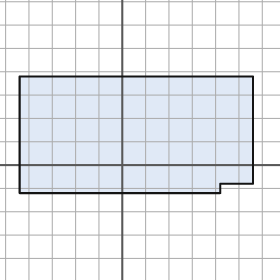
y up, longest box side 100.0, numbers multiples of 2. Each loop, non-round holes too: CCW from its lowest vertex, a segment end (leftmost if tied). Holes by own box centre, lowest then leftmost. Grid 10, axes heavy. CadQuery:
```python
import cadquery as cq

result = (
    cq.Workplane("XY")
    .moveTo(-44.0, -12.0)
    .lineTo(42.0, -12.0)
    .lineTo(42.0, -8.0)
    .lineTo(56.0, -8.0)
    .lineTo(56.0, 38.0)
    .lineTo(-44.0, 38.0)
    .close()
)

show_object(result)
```